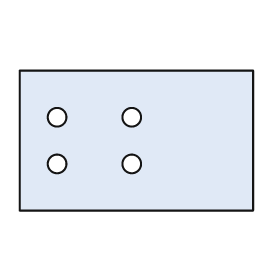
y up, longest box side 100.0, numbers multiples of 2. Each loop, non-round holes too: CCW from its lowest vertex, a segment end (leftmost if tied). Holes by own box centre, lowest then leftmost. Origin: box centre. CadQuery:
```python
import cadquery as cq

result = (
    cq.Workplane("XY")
    .moveTo(-50.0, -30.0)
    .lineTo(50.0, -30.0)
    .lineTo(50.0, 30.0)
    .lineTo(-50.0, 30.0)
    .close()
    .moveTo(-34.0, -10.0)
    .circle(4.0)
    .moveTo(-2.0, -10.0)
    .circle(4.0)
    .moveTo(-34.0, 10.0)
    .circle(4.0)
    .moveTo(-2.0, 10.0)
    .circle(4.0)
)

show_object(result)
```